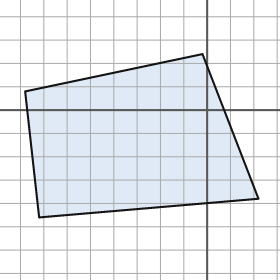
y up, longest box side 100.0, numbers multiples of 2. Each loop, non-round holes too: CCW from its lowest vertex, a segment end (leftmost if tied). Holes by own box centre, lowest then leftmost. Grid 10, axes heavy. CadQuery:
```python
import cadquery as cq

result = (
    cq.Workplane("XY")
    .moveTo(-72.0, -46.0)
    .lineTo(22.0, -38.0)
    .lineTo(-2.0, 24.0)
    .lineTo(-78.0, 8.0)
    .close()
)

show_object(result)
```